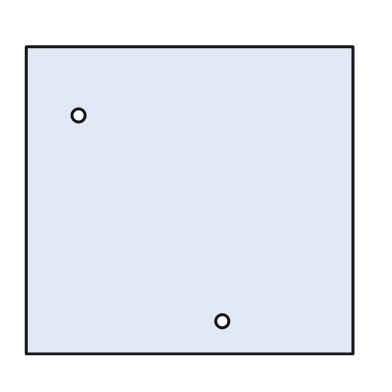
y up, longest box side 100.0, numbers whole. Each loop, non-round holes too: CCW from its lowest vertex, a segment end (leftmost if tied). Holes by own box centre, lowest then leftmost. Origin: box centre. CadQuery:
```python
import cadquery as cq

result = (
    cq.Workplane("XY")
    .moveTo(-50.0, -47.0)
    .lineTo(50.0, -47.0)
    .lineTo(50.0, 47.0)
    .lineTo(-50.0, 47.0)
    .close()
    .moveTo(10.0, -37.0)
    .circle(2.0)
    .moveTo(-34.0, 26.0)
    .circle(2.0)
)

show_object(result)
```